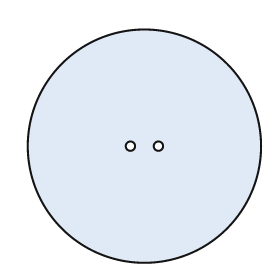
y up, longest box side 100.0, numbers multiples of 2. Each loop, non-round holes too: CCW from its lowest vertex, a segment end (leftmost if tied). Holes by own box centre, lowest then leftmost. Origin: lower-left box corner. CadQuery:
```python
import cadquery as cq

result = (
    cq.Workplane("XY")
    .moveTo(50.0, 50.0)
    .circle(50.0)
    .moveTo(44.0, 50.0)
    .circle(2.0)
    .moveTo(56.0, 50.0)
    .circle(2.0)
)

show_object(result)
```